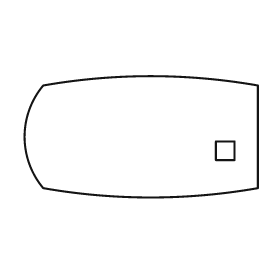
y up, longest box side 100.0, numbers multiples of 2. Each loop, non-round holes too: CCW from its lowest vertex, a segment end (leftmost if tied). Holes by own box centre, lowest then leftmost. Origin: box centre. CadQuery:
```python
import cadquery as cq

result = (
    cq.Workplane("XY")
    .moveTo(-42.0, -22.0)
    .threePointArc((4.0, -26.0), (50.0, -22.0))
    .lineTo(50.0, 22.0)
    .threePointArc((4.0, 26.0), (-42.0, 22.0))
    .threePointArc((-50.0, 0.0), (-42.0, -22.0))
    .close()
    .moveTo(32.0, -10.0)
    .lineTo(40.0, -10.0)
    .lineTo(40.0, -2.0)
    .lineTo(32.0, -2.0)
    .close()
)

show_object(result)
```